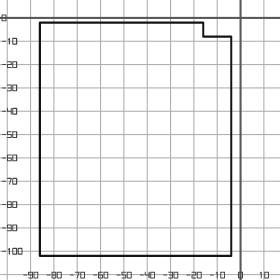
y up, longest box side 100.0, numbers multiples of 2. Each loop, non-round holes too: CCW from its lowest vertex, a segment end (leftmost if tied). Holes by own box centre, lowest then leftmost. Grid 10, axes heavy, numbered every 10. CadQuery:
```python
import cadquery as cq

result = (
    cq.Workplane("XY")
    .moveTo(-86.0, -102.0)
    .lineTo(-4.0, -102.0)
    .lineTo(-4.0, -8.0)
    .lineTo(-16.0, -8.0)
    .lineTo(-16.0, -2.0)
    .lineTo(-86.0, -2.0)
    .close()
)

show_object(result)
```